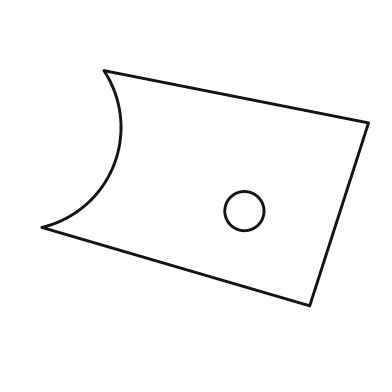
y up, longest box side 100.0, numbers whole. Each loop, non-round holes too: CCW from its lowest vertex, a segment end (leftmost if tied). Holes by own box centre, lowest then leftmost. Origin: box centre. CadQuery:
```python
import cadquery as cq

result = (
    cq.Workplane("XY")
    .moveTo(32.0, -36.0)
    .lineTo(50.0, 20.0)
    .lineTo(-31.0, 36.0)
    .threePointArc((-28.0, 7.0), (-50.0, -12.0))
    .close()
    .moveTo(12.0, -7.0)
    .circle(6.0)
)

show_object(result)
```